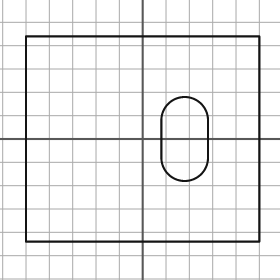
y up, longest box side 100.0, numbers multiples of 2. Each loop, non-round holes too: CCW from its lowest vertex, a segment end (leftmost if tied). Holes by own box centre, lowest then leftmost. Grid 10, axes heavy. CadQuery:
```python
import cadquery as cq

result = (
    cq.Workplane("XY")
    .moveTo(-50.0, -44.0)
    .lineTo(50.0, -44.0)
    .lineTo(50.0, 44.0)
    .lineTo(-50.0, 44.0)
    .close()
    .moveTo(8.0, -8.0)
    .threePointArc((18.0, -18.0), (28.0, -8.0))
    .lineTo(28.0, 8.0)
    .threePointArc((18.0, 18.0), (8.0, 8.0))
    .close()
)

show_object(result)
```